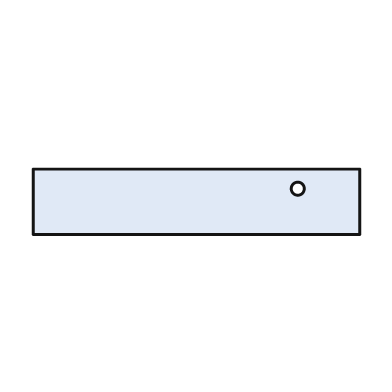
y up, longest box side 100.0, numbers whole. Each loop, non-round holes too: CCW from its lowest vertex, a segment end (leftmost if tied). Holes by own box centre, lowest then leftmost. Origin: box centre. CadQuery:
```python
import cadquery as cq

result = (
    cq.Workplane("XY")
    .moveTo(-50.0, -10.0)
    .lineTo(50.0, -10.0)
    .lineTo(50.0, 10.0)
    .lineTo(-50.0, 10.0)
    .close()
    .moveTo(31.0, 4.0)
    .circle(2.0)
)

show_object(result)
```